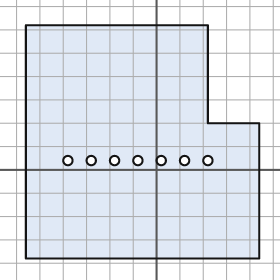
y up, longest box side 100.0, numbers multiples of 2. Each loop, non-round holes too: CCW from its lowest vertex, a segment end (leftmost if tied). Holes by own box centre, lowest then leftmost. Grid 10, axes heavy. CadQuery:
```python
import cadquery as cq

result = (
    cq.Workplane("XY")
    .moveTo(-56.0, -38.0)
    .lineTo(44.0, -38.0)
    .lineTo(44.0, 20.0)
    .lineTo(22.0, 20.0)
    .lineTo(22.0, 62.0)
    .lineTo(-56.0, 62.0)
    .close()
    .moveTo(-38.0, 4.0)
    .circle(2.0)
    .moveTo(-28.0, 4.0)
    .circle(2.0)
    .moveTo(-18.0, 4.0)
    .circle(2.0)
    .moveTo(-8.0, 4.0)
    .circle(2.0)
    .moveTo(2.0, 4.0)
    .circle(2.0)
    .moveTo(12.0, 4.0)
    .circle(2.0)
    .moveTo(22.0, 4.0)
    .circle(2.0)
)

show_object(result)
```